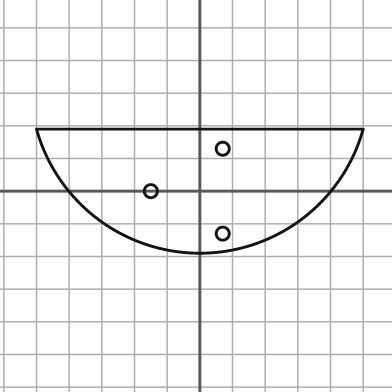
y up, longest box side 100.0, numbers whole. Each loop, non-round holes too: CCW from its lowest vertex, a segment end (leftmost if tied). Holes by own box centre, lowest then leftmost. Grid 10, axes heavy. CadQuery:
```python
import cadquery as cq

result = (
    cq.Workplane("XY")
    .moveTo(-50.0, 19.0)
    .threePointArc((0.0, -19.0), (50.0, 19.0))
    .close()
    .moveTo(7.0, -13.0)
    .circle(2.0)
    .moveTo(-15.0, 0.0)
    .circle(2.0)
    .moveTo(7.0, 13.0)
    .circle(2.0)
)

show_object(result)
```